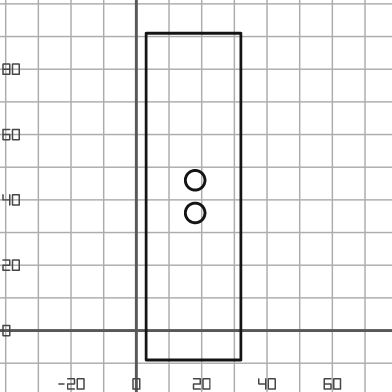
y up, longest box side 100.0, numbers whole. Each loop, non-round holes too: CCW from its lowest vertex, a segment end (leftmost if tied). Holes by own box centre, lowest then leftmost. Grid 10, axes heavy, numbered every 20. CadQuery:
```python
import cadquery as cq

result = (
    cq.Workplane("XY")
    .moveTo(3.0, -9.0)
    .lineTo(32.0, -9.0)
    .lineTo(32.0, 91.0)
    .lineTo(3.0, 91.0)
    .close()
    .moveTo(18.0, 36.0)
    .circle(3.0)
    .moveTo(18.0, 46.0)
    .circle(3.0)
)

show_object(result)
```